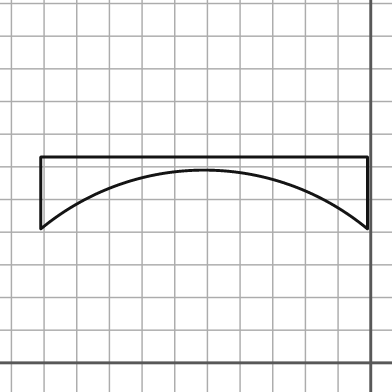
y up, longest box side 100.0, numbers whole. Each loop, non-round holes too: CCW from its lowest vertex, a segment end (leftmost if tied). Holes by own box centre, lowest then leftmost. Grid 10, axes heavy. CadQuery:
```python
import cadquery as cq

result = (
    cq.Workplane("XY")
    .moveTo(-101.0, 41.0)
    .threePointArc((-51.0, 59.0), (-1.0, 41.0))
    .lineTo(-1.0, 63.0)
    .lineTo(-101.0, 63.0)
    .close()
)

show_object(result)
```